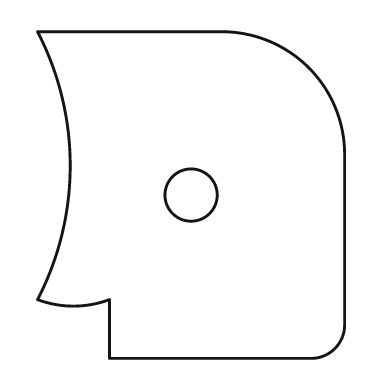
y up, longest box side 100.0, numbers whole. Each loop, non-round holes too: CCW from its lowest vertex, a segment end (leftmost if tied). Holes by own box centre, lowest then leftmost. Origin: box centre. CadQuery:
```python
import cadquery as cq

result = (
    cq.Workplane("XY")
    .moveTo(-25.0, -50.0)
    .lineTo(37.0, -50.0)
    .threePointArc((44.0, -47.0), (47.0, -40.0))
    .lineTo(47.0, 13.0)
    .threePointArc((36.0, 39.0), (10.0, 50.0))
    .lineTo(-47.0, 50.0)
    .threePointArc((-37.0, 9.0), (-47.0, -32.0))
    .threePointArc((-36.0, -34.0), (-25.0, -32.0))
    .close()
    .moveTo(0.0, 0.0)
    .circle(8.0)
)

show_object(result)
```